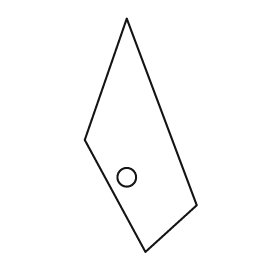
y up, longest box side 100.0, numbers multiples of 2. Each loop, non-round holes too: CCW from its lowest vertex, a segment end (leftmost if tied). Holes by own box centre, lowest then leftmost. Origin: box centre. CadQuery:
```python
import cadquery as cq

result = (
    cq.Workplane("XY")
    .moveTo(2.0, -50.0)
    .lineTo(24.0, -30.0)
    .lineTo(-6.0, 50.0)
    .lineTo(-24.0, -2.0)
    .close()
    .moveTo(-6.0, -18.0)
    .circle(4.0)
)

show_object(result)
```